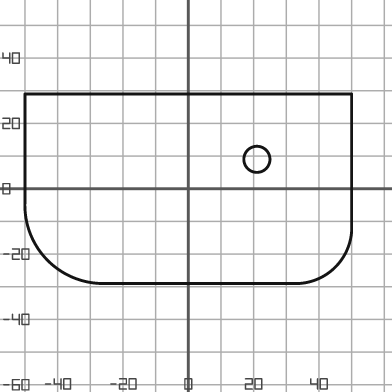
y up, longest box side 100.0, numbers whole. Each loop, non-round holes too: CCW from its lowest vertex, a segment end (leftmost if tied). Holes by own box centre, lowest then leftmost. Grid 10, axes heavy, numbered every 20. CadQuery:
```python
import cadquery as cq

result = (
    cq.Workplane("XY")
    .moveTo(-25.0, -29.0)
    .lineTo(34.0, -29.0)
    .threePointArc((45.0, -24.0), (50.0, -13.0))
    .lineTo(50.0, 29.0)
    .lineTo(-50.0, 29.0)
    .lineTo(-50.0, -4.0)
    .threePointArc((-43.0, -22.0), (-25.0, -29.0))
    .close()
    .moveTo(21.0, 9.0)
    .circle(4.0)
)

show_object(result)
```